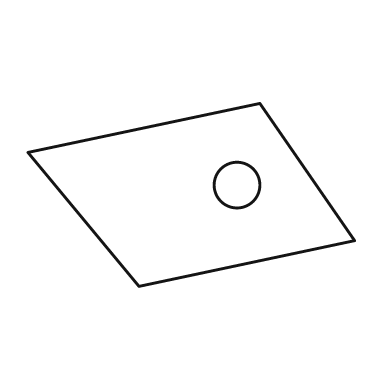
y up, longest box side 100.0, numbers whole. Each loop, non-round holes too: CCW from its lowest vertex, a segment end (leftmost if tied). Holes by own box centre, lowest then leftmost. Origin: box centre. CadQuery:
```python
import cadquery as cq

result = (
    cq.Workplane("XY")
    .moveTo(-16.0, -28.0)
    .lineTo(50.0, -14.0)
    .lineTo(21.0, 28.0)
    .lineTo(-50.0, 13.0)
    .close()
    .moveTo(14.0, 3.0)
    .circle(7.0)
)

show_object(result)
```